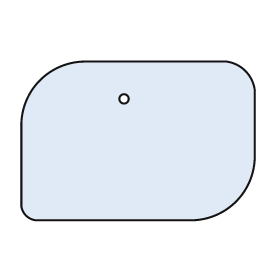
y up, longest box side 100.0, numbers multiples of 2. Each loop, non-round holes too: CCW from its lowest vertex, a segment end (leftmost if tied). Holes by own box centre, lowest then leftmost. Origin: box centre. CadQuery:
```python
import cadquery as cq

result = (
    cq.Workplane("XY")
    .moveTo(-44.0, -34.0)
    .lineTo(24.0, -34.0)
    .threePointArc((42.0, -26.0), (50.0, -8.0))
    .lineTo(50.0, 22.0)
    .threePointArc((46.0, 30.0), (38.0, 34.0))
    .lineTo(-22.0, 34.0)
    .threePointArc((-42.0, 26.0), (-50.0, 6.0))
    .lineTo(-50.0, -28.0)
    .threePointArc((-48.0, -32.0), (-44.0, -34.0))
    .close()
    .moveTo(-6.0, 18.0)
    .circle(2.0)
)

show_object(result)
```